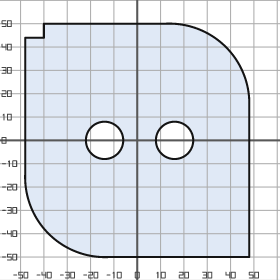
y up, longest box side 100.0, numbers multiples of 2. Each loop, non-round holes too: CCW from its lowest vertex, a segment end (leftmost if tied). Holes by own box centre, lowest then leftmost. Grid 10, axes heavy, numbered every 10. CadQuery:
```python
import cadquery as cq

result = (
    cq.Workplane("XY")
    .moveTo(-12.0, -50.0)
    .lineTo(48.0, -50.0)
    .lineTo(48.0, 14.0)
    .threePointArc((38.0, 40.0), (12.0, 50.0))
    .lineTo(-40.0, 50.0)
    .lineTo(-40.0, 44.0)
    .lineTo(-48.0, 44.0)
    .lineTo(-48.0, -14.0)
    .threePointArc((-38.0, -40.0), (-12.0, -50.0))
    .close()
    .moveTo(-14.0, 0.0)
    .circle(8.0)
    .moveTo(16.0, 0.0)
    .circle(8.0)
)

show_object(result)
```